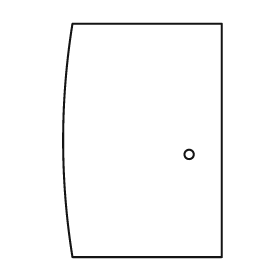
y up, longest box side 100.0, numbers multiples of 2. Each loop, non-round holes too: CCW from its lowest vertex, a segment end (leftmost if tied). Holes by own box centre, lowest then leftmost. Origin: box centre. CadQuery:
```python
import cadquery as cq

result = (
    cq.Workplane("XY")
    .moveTo(-30.0, -50.0)
    .lineTo(34.0, -50.0)
    .lineTo(34.0, 50.0)
    .lineTo(-30.0, 50.0)
    .threePointArc((-34.0, 0.0), (-30.0, -50.0))
    .close()
    .moveTo(20.0, -6.0)
    .circle(2.0)
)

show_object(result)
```